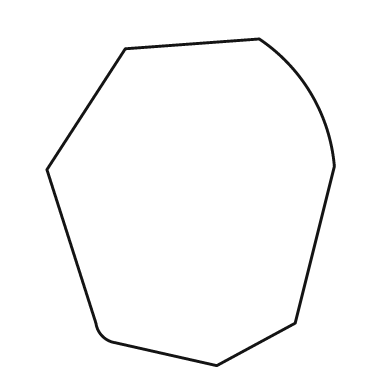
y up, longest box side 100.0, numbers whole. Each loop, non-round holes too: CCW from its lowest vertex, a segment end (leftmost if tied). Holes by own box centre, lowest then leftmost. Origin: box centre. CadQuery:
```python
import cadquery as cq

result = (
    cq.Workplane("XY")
    .moveTo(8.0, -50.0)
    .lineTo(32.0, -37.0)
    .lineTo(44.0, 11.0)
    .threePointArc((37.0, 33.0), (21.0, 50.0))
    .lineTo(-20.0, 47.0)
    .lineTo(-44.0, 10.0)
    .lineTo(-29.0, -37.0)
    .threePointArc((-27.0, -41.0), (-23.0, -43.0))
    .close()
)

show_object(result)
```